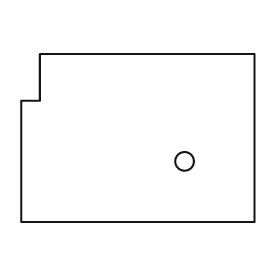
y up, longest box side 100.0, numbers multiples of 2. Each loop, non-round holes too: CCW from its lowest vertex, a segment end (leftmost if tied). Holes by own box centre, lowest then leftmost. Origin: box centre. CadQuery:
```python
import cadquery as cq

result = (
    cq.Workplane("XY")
    .moveTo(-50.0, -36.0)
    .lineTo(50.0, -36.0)
    .lineTo(50.0, 36.0)
    .lineTo(-42.0, 36.0)
    .lineTo(-42.0, 16.0)
    .lineTo(-50.0, 16.0)
    .close()
    .moveTo(20.0, -10.0)
    .circle(4.0)
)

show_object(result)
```